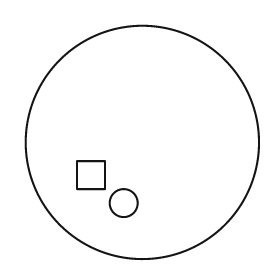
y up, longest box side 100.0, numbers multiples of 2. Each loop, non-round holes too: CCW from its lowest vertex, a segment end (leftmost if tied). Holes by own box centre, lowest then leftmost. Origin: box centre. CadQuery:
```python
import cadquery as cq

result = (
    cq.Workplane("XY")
    .moveTo(0.0, 0.0)
    .circle(50.0)
    .moveTo(-8.0, -26.0)
    .circle(6.0)
    .moveTo(-28.0, -20.0)
    .lineTo(-16.0, -20.0)
    .lineTo(-16.0, -8.0)
    .lineTo(-28.0, -8.0)
    .close()
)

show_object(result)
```